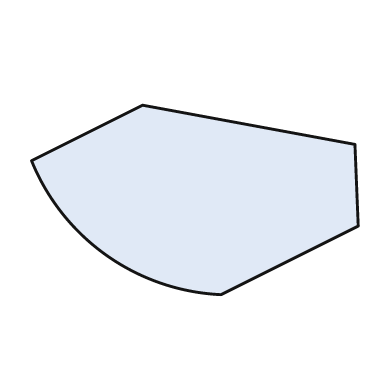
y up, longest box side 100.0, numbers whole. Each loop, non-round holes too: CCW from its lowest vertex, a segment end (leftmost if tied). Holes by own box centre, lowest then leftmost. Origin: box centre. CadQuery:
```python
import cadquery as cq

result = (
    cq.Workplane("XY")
    .moveTo(8.0, -29.0)
    .lineTo(50.0, -8.0)
    .lineTo(49.0, 17.0)
    .lineTo(-16.0, 29.0)
    .lineTo(-50.0, 12.0)
    .threePointArc((-27.0, -17.0), (8.0, -29.0))
    .close()
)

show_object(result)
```